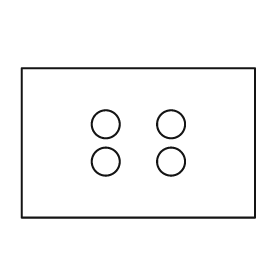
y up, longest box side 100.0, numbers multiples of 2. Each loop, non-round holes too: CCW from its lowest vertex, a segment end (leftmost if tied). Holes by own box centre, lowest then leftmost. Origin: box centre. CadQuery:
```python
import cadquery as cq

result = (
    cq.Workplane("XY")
    .moveTo(-50.0, -32.0)
    .lineTo(50.0, -32.0)
    .lineTo(50.0, 32.0)
    .lineTo(-50.0, 32.0)
    .close()
    .moveTo(-14.0, -8.0)
    .circle(6.0)
    .moveTo(14.0, -8.0)
    .circle(6.0)
    .moveTo(-14.0, 8.0)
    .circle(6.0)
    .moveTo(14.0, 8.0)
    .circle(6.0)
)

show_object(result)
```